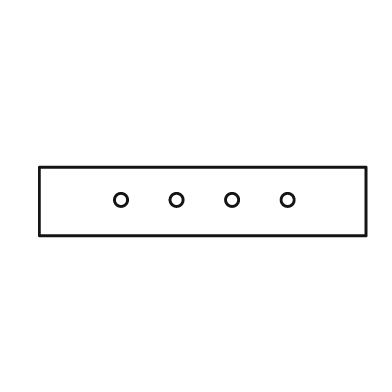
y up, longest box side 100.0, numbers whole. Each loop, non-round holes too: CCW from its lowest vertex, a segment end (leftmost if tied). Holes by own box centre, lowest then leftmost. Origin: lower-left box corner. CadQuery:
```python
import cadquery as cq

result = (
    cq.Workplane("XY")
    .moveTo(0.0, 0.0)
    .lineTo(100.0, 0.0)
    .lineTo(100.0, 21.0)
    .lineTo(0.0, 21.0)
    .close()
    .moveTo(25.0, 11.0)
    .circle(2.0)
    .moveTo(42.0, 11.0)
    .circle(2.0)
    .moveTo(59.0, 11.0)
    .circle(2.0)
    .moveTo(76.0, 11.0)
    .circle(2.0)
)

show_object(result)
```